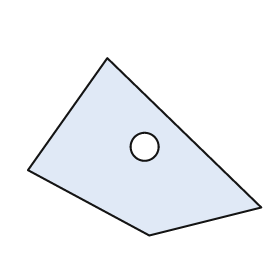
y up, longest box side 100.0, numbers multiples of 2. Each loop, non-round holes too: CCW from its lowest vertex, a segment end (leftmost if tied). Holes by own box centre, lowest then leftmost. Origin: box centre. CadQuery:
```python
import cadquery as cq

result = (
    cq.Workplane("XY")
    .moveTo(2.0, -38.0)
    .lineTo(50.0, -26.0)
    .lineTo(-16.0, 38.0)
    .lineTo(-50.0, -10.0)
    .close()
    .moveTo(0.0, 0.0)
    .circle(6.0)
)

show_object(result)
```